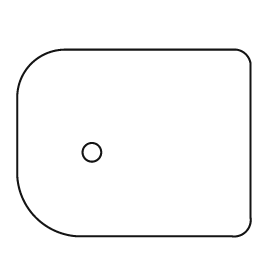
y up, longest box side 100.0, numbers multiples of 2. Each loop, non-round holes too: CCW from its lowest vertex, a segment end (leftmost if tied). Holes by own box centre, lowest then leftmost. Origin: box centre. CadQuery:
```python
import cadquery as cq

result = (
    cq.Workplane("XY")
    .moveTo(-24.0, -40.0)
    .lineTo(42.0, -40.0)
    .threePointArc((48.0, -38.0), (50.0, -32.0))
    .lineTo(50.0, 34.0)
    .threePointArc((48.0, 38.0), (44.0, 40.0))
    .lineTo(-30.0, 40.0)
    .threePointArc((-44.0, 34.0), (-50.0, 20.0))
    .lineTo(-50.0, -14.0)
    .threePointArc((-42.0, -32.0), (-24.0, -40.0))
    .close()
    .moveTo(-18.0, -4.0)
    .circle(4.0)
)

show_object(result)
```